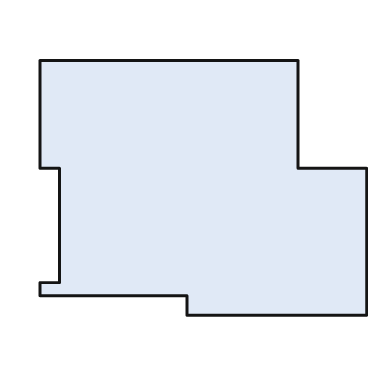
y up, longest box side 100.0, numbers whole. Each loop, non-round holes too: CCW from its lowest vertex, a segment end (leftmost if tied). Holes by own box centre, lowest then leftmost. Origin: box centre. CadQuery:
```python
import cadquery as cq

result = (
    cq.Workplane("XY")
    .moveTo(-5.0, -39.0)
    .lineTo(50.0, -39.0)
    .lineTo(50.0, 6.0)
    .lineTo(29.0, 6.0)
    .lineTo(29.0, 39.0)
    .lineTo(-50.0, 39.0)
    .lineTo(-50.0, 6.0)
    .lineTo(-44.0, 6.0)
    .lineTo(-44.0, -29.0)
    .lineTo(-50.0, -29.0)
    .lineTo(-50.0, -33.0)
    .lineTo(-5.0, -33.0)
    .close()
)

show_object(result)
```